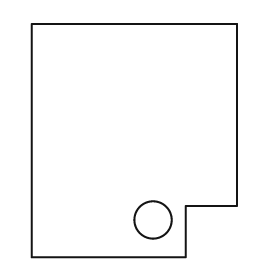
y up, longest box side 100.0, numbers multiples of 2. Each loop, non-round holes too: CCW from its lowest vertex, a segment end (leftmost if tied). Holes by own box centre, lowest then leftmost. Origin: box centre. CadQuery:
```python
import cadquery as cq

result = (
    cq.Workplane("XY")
    .moveTo(-44.0, -50.0)
    .lineTo(22.0, -50.0)
    .lineTo(22.0, -28.0)
    .lineTo(44.0, -28.0)
    .lineTo(44.0, 50.0)
    .lineTo(-44.0, 50.0)
    .close()
    .moveTo(8.0, -34.0)
    .circle(8.0)
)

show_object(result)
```